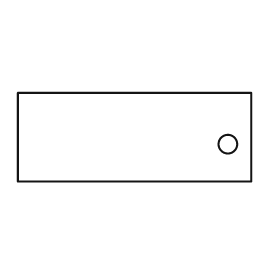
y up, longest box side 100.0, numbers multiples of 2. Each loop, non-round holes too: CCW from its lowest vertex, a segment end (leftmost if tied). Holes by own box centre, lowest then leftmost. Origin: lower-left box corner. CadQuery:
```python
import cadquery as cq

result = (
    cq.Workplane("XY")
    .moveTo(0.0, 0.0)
    .lineTo(100.0, 0.0)
    .lineTo(100.0, 38.0)
    .lineTo(0.0, 38.0)
    .close()
    .moveTo(90.0, 16.0)
    .circle(4.0)
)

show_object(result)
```